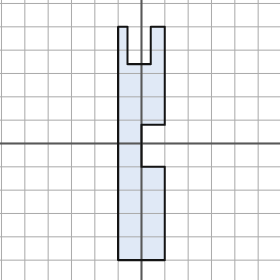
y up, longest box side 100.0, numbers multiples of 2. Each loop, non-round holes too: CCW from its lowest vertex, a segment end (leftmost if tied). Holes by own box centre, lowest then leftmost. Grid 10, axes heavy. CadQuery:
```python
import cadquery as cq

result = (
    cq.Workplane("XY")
    .moveTo(-10.0, -50.0)
    .lineTo(10.0, -50.0)
    .lineTo(10.0, -10.0)
    .lineTo(0.0, -10.0)
    .lineTo(0.0, 8.0)
    .lineTo(10.0, 8.0)
    .lineTo(10.0, 50.0)
    .lineTo(4.0, 50.0)
    .lineTo(4.0, 34.0)
    .lineTo(-6.0, 34.0)
    .lineTo(-6.0, 50.0)
    .lineTo(-10.0, 50.0)
    .close()
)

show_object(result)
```